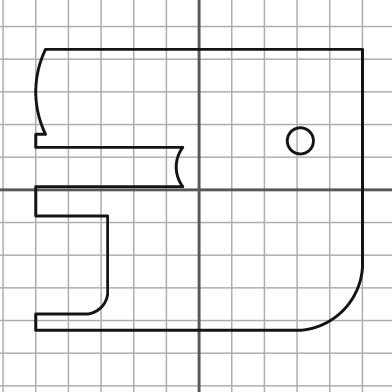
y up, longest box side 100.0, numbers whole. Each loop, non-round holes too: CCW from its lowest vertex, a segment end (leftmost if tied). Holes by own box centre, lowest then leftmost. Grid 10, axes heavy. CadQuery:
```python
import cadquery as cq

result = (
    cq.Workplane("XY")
    .moveTo(-50.0, -43.0)
    .lineTo(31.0, -43.0)
    .threePointArc((44.0, -37.0), (50.0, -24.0))
    .lineTo(50.0, 43.0)
    .lineTo(-47.0, 43.0)
    .threePointArc((-50.0, 30.0), (-47.0, 17.0))
    .lineTo(-50.0, 17.0)
    .lineTo(-50.0, 13.0)
    .lineTo(-5.0, 13.0)
    .threePointArc((-7.0, 7.0), (-5.0, 1.0))
    .lineTo(-50.0, 1.0)
    .lineTo(-50.0, -8.0)
    .lineTo(-28.0, -8.0)
    .lineTo(-28.0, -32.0)
    .threePointArc((-30.0, -36.0), (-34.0, -38.0))
    .lineTo(-50.0, -38.0)
    .close()
    .moveTo(31.0, 15.0)
    .circle(4.0)
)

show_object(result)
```